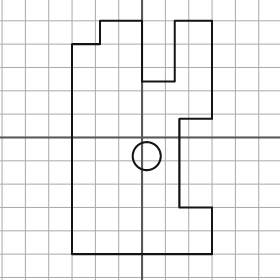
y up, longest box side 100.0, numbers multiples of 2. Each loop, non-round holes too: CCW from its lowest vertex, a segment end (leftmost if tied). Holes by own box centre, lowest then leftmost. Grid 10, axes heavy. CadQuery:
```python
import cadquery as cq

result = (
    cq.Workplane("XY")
    .moveTo(-30.0, -50.0)
    .lineTo(30.0, -50.0)
    .lineTo(30.0, -30.0)
    .lineTo(16.0, -30.0)
    .lineTo(16.0, 8.0)
    .lineTo(30.0, 8.0)
    .lineTo(30.0, 50.0)
    .lineTo(14.0, 50.0)
    .lineTo(14.0, 24.0)
    .lineTo(0.0, 24.0)
    .lineTo(0.0, 50.0)
    .lineTo(-18.0, 50.0)
    .lineTo(-18.0, 40.0)
    .lineTo(-30.0, 40.0)
    .close()
    .moveTo(2.0, -8.0)
    .circle(6.0)
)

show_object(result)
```